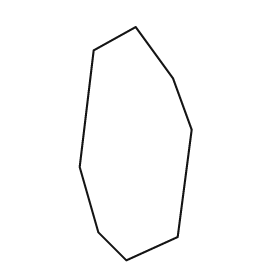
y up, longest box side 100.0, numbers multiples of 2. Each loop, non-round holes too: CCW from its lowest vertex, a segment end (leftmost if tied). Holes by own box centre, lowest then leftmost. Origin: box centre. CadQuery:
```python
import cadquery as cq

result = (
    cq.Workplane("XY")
    .moveTo(-4.0, -50.0)
    .lineTo(18.0, -40.0)
    .lineTo(24.0, 6.0)
    .lineTo(16.0, 28.0)
    .lineTo(0.0, 50.0)
    .lineTo(-18.0, 40.0)
    .lineTo(-24.0, -10.0)
    .lineTo(-16.0, -38.0)
    .close()
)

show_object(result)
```